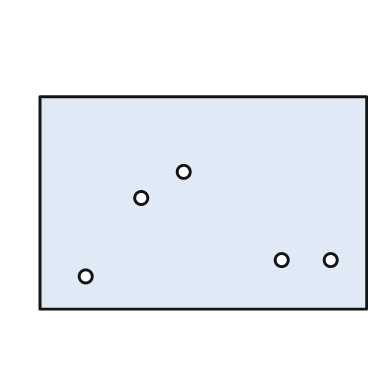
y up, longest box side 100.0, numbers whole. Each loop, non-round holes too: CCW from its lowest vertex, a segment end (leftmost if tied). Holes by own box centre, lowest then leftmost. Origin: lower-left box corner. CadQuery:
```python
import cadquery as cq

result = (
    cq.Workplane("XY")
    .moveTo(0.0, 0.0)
    .lineTo(100.0, 0.0)
    .lineTo(100.0, 65.0)
    .lineTo(0.0, 65.0)
    .close()
    .moveTo(14.0, 10.0)
    .circle(2.0)
    .moveTo(74.0, 15.0)
    .circle(2.0)
    .moveTo(89.0, 15.0)
    .circle(2.0)
    .moveTo(31.0, 34.0)
    .circle(2.0)
    .moveTo(44.0, 42.0)
    .circle(2.0)
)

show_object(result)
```